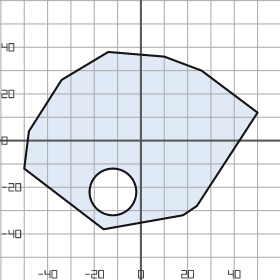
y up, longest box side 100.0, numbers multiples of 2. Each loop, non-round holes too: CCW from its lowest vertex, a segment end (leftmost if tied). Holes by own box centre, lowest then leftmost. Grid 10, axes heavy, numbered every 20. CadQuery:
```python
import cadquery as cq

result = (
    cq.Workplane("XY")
    .moveTo(-16.0, -38.0)
    .lineTo(18.0, -32.0)
    .lineTo(24.0, -28.0)
    .lineTo(50.0, 12.0)
    .lineTo(26.0, 30.0)
    .lineTo(10.0, 36.0)
    .lineTo(-14.0, 38.0)
    .lineTo(-34.0, 26.0)
    .lineTo(-48.0, 4.0)
    .lineTo(-50.0, -12.0)
    .close()
    .moveTo(-12.0, -22.0)
    .circle(10.0)
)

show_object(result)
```